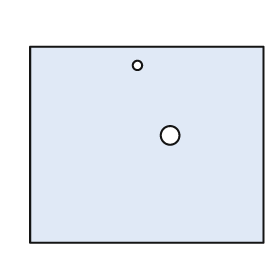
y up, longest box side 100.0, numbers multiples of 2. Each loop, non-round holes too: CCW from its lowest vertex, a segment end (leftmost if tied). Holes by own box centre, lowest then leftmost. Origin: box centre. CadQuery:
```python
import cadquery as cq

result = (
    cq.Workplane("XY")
    .moveTo(-50.0, -42.0)
    .lineTo(50.0, -42.0)
    .lineTo(50.0, 42.0)
    .lineTo(-50.0, 42.0)
    .close()
    .moveTo(10.0, 4.0)
    .circle(4.0)
    .moveTo(-4.0, 34.0)
    .circle(2.0)
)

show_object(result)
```